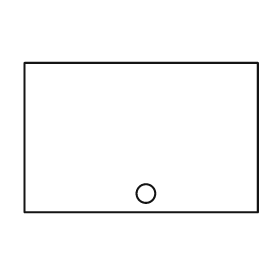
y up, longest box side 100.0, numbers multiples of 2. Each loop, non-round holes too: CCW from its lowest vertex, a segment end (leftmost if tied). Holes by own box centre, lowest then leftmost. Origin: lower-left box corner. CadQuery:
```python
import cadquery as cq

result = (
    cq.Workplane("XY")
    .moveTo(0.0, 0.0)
    .lineTo(100.0, 0.0)
    .lineTo(100.0, 64.0)
    .lineTo(0.0, 64.0)
    .close()
    .moveTo(52.0, 8.0)
    .circle(4.0)
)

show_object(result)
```